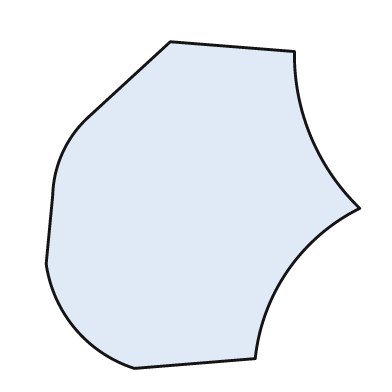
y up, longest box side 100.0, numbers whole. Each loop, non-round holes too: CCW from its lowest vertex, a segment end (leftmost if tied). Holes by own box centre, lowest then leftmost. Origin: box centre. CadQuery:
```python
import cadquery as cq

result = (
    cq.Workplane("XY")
    .moveTo(-21.0, -50.0)
    .lineTo(16.0, -47.0)
    .threePointArc((26.0, -20.0), (48.0, -1.0))
    .threePointArc((33.0, 21.0), (28.0, 47.0))
    .lineTo(-10.0, 50.0)
    .lineTo(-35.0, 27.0)
    .threePointArc((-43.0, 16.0), (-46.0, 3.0))
    .lineTo(-48.0, -18.0)
    .threePointArc((-39.0, -38.0), (-21.0, -50.0))
    .close()
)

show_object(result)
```